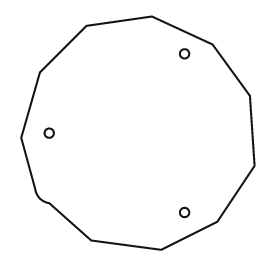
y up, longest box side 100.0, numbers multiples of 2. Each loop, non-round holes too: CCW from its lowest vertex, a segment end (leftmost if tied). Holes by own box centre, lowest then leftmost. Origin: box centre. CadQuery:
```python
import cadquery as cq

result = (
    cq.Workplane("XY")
    .moveTo(10.0, -50.0)
    .lineTo(34.0, -38.0)
    .lineTo(50.0, -14.0)
    .lineTo(48.0, 16.0)
    .lineTo(32.0, 38.0)
    .lineTo(6.0, 50.0)
    .lineTo(-22.0, 46.0)
    .lineTo(-42.0, 26.0)
    .lineTo(-50.0, -2.0)
    .lineTo(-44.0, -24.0)
    .threePointArc((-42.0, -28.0), (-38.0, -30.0))
    .lineTo(-20.0, -46.0)
    .close()
    .moveTo(20.0, -34.0)
    .circle(2.0)
    .moveTo(-38.0, 0.0)
    .circle(2.0)
    .moveTo(20.0, 34.0)
    .circle(2.0)
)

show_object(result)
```